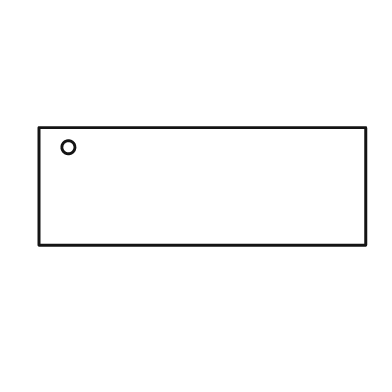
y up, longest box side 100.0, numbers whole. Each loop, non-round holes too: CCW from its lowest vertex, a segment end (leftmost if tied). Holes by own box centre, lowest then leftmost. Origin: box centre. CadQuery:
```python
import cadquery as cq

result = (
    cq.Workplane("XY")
    .moveTo(-50.0, -18.0)
    .lineTo(50.0, -18.0)
    .lineTo(50.0, 18.0)
    .lineTo(-50.0, 18.0)
    .close()
    .moveTo(-41.0, 12.0)
    .circle(2.0)
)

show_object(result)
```